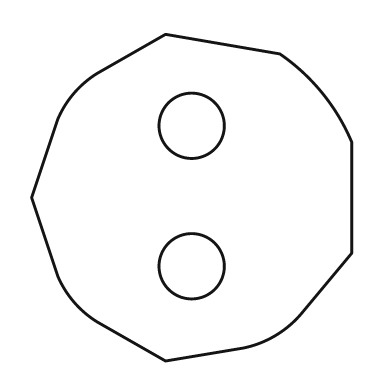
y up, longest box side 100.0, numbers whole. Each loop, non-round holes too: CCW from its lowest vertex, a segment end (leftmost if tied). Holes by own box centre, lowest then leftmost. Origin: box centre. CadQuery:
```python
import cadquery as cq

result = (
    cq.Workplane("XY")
    .moveTo(-8.0, -50.0)
    .lineTo(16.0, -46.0)
    .threePointArc((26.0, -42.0), (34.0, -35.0))
    .lineTo(49.0, -17.0)
    .lineTo(49.0, 17.0)
    .threePointArc((40.0, 32.0), (27.0, 44.0))
    .lineTo(-8.0, 50.0)
    .lineTo(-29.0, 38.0)
    .threePointArc((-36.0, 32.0), (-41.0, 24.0))
    .lineTo(-49.0, 0.0)
    .lineTo(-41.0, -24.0)
    .threePointArc((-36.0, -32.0), (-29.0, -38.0))
    .close()
    .moveTo(0.0, -21.0)
    .circle(10.0)
    .moveTo(0.0, 22.0)
    .circle(10.0)
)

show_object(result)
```